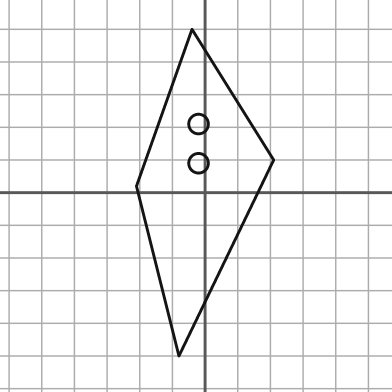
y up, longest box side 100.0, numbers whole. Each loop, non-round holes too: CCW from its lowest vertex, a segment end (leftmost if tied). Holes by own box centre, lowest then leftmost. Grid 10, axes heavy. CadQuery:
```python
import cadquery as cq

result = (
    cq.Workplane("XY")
    .moveTo(-8.0, -50.0)
    .lineTo(21.0, 10.0)
    .lineTo(-4.0, 50.0)
    .lineTo(-21.0, 2.0)
    .close()
    .moveTo(-2.0, 9.0)
    .circle(3.0)
    .moveTo(-2.0, 21.0)
    .circle(3.0)
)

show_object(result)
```